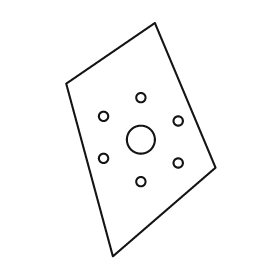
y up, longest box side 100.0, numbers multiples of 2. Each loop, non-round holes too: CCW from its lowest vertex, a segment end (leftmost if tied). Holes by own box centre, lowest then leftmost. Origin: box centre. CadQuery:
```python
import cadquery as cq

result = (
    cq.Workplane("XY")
    .moveTo(-12.0, -50.0)
    .lineTo(32.0, -12.0)
    .lineTo(6.0, 50.0)
    .lineTo(-32.0, 24.0)
    .close()
    .moveTo(0.0, -18.0)
    .circle(2.0)
    .moveTo(16.0, -10.0)
    .circle(2.0)
    .moveTo(-16.0, -8.0)
    .circle(2.0)
    .moveTo(0.0, 0.0)
    .circle(6.0)
    .moveTo(16.0, 8.0)
    .circle(2.0)
    .moveTo(-16.0, 10.0)
    .circle(2.0)
    .moveTo(0.0, 18.0)
    .circle(2.0)
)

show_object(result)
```